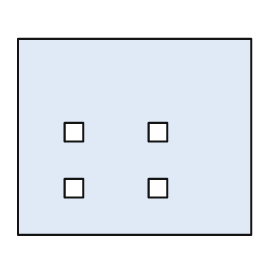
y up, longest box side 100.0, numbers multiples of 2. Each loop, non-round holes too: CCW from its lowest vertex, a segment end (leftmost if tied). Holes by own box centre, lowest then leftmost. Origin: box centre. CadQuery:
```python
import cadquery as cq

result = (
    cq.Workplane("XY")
    .moveTo(-50.0, -42.0)
    .lineTo(50.0, -42.0)
    .lineTo(50.0, 42.0)
    .lineTo(-50.0, 42.0)
    .close()
    .moveTo(-30.0, -26.0)
    .lineTo(-22.0, -26.0)
    .lineTo(-22.0, -18.0)
    .lineTo(-30.0, -18.0)
    .close()
    .moveTo(6.0, -26.0)
    .lineTo(14.0, -26.0)
    .lineTo(14.0, -18.0)
    .lineTo(6.0, -18.0)
    .close()
    .moveTo(-30.0, -2.0)
    .lineTo(-22.0, -2.0)
    .lineTo(-22.0, 6.0)
    .lineTo(-30.0, 6.0)
    .close()
    .moveTo(6.0, -2.0)
    .lineTo(14.0, -2.0)
    .lineTo(14.0, 6.0)
    .lineTo(6.0, 6.0)
    .close()
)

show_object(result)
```